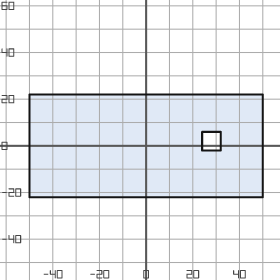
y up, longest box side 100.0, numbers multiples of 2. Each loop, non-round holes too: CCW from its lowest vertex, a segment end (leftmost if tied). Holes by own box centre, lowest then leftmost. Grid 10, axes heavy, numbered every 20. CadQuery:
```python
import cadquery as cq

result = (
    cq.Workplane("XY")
    .moveTo(-50.0, -22.0)
    .lineTo(50.0, -22.0)
    .lineTo(50.0, 22.0)
    .lineTo(-50.0, 22.0)
    .close()
    .moveTo(24.0, -2.0)
    .lineTo(32.0, -2.0)
    .lineTo(32.0, 6.0)
    .lineTo(24.0, 6.0)
    .close()
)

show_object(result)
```